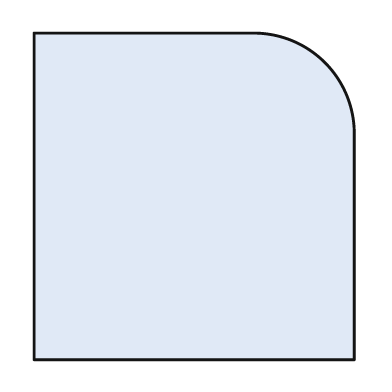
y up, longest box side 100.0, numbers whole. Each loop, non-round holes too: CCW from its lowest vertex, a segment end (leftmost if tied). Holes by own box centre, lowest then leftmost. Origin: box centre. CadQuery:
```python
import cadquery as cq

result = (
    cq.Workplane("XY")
    .moveTo(-49.0, -50.0)
    .lineTo(49.0, -50.0)
    .lineTo(49.0, 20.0)
    .threePointArc((40.0, 41.0), (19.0, 50.0))
    .lineTo(-49.0, 50.0)
    .close()
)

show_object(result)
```